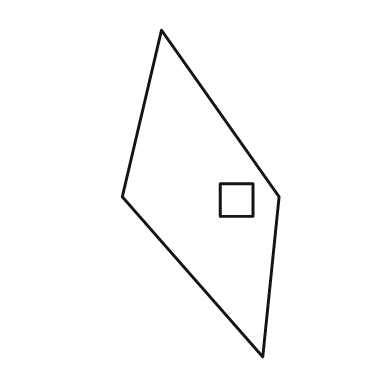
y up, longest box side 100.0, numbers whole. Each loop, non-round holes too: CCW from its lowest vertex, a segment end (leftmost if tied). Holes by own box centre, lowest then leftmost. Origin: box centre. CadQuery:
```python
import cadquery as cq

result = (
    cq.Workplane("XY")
    .moveTo(19.0, -50.0)
    .lineTo(24.0, -1.0)
    .lineTo(-12.0, 50.0)
    .lineTo(-24.0, -1.0)
    .close()
    .moveTo(6.0, -7.0)
    .lineTo(16.0, -7.0)
    .lineTo(16.0, 3.0)
    .lineTo(6.0, 3.0)
    .close()
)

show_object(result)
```